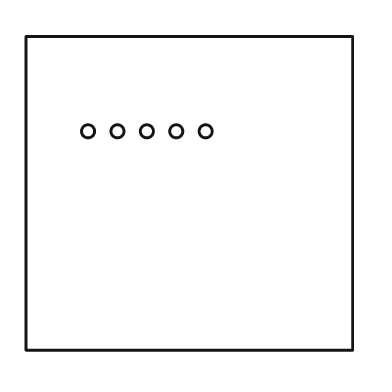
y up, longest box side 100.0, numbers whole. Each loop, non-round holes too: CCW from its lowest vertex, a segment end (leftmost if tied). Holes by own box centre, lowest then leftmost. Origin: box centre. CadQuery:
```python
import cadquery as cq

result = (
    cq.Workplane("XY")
    .moveTo(-50.0, -48.0)
    .lineTo(50.0, -48.0)
    .lineTo(50.0, 48.0)
    .lineTo(-50.0, 48.0)
    .close()
    .moveTo(-31.0, 19.0)
    .circle(2.0)
    .moveTo(-22.0, 19.0)
    .circle(2.0)
    .moveTo(-13.0, 19.0)
    .circle(2.0)
    .moveTo(-4.0, 19.0)
    .circle(2.0)
    .moveTo(5.0, 19.0)
    .circle(2.0)
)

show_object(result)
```